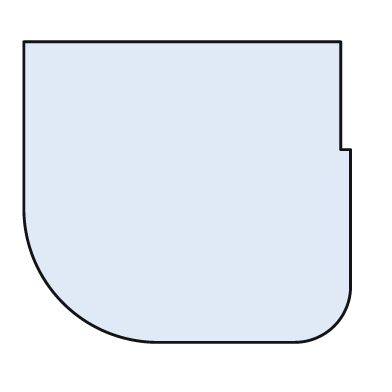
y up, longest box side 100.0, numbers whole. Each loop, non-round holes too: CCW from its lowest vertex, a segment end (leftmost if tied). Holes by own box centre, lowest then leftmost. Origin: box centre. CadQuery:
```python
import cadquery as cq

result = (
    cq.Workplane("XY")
    .moveTo(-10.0, -46.0)
    .lineTo(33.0, -46.0)
    .threePointArc((45.0, -41.0), (50.0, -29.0))
    .lineTo(50.0, 13.0)
    .lineTo(47.0, 13.0)
    .lineTo(47.0, 46.0)
    .lineTo(-50.0, 46.0)
    .lineTo(-50.0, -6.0)
    .threePointArc((-38.0, -34.0), (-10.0, -46.0))
    .close()
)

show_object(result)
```